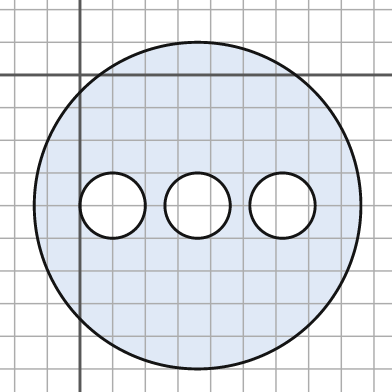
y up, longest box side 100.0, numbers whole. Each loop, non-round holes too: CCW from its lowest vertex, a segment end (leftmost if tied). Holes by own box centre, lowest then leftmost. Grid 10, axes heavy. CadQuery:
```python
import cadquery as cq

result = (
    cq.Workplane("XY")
    .moveTo(36.0, -40.0)
    .circle(50.0)
    .moveTo(10.0, -40.0)
    .circle(10.0)
    .moveTo(36.0, -40.0)
    .circle(10.0)
    .moveTo(62.0, -40.0)
    .circle(10.0)
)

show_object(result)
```